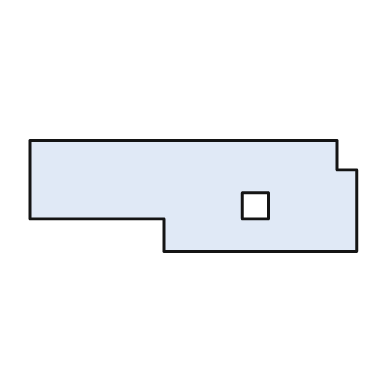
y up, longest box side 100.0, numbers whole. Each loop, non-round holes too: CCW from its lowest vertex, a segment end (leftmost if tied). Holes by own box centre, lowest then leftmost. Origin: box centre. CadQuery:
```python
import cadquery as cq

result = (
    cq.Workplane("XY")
    .moveTo(-9.0, -17.0)
    .lineTo(50.0, -17.0)
    .lineTo(50.0, 8.0)
    .lineTo(44.0, 8.0)
    .lineTo(44.0, 17.0)
    .lineTo(-50.0, 17.0)
    .lineTo(-50.0, -7.0)
    .lineTo(-9.0, -7.0)
    .close()
    .moveTo(15.0, -7.0)
    .lineTo(23.0, -7.0)
    .lineTo(23.0, 1.0)
    .lineTo(15.0, 1.0)
    .close()
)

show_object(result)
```